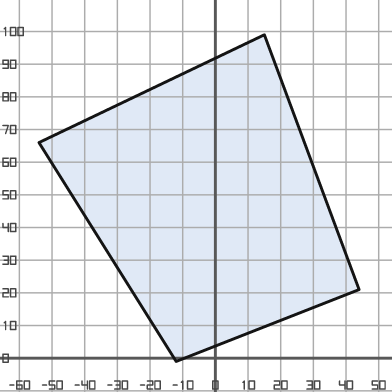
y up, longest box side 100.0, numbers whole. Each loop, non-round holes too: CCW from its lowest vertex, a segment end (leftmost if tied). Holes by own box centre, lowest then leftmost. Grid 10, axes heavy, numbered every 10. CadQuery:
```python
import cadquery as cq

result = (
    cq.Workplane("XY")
    .moveTo(-12.0, -1.0)
    .lineTo(44.0, 21.0)
    .lineTo(15.0, 99.0)
    .lineTo(-54.0, 66.0)
    .close()
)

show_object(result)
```